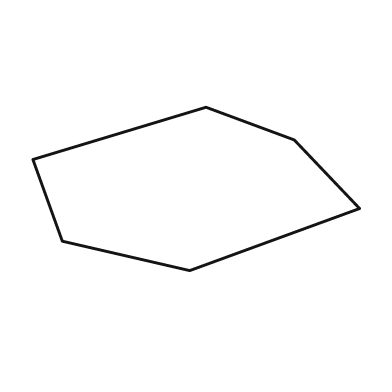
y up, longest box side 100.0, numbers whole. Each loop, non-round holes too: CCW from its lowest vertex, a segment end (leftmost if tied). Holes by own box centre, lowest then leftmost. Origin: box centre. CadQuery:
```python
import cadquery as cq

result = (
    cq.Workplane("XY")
    .moveTo(-2.0, -25.0)
    .lineTo(50.0, -6.0)
    .lineTo(30.0, 15.0)
    .lineTo(3.0, 25.0)
    .lineTo(-50.0, 9.0)
    .lineTo(-41.0, -16.0)
    .close()
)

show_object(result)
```